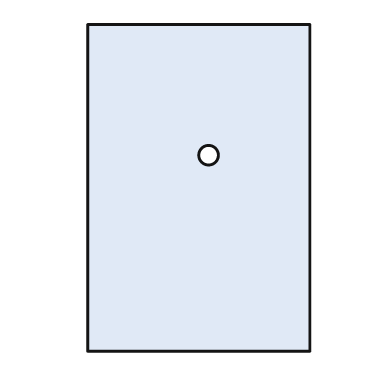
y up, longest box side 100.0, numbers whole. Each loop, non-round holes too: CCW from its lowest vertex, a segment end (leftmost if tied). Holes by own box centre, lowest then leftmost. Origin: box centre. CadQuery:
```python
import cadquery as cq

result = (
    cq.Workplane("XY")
    .moveTo(-34.0, -50.0)
    .lineTo(34.0, -50.0)
    .lineTo(34.0, 50.0)
    .lineTo(-34.0, 50.0)
    .close()
    .moveTo(3.0, 10.0)
    .circle(3.0)
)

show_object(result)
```